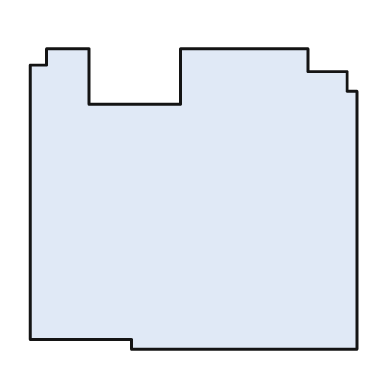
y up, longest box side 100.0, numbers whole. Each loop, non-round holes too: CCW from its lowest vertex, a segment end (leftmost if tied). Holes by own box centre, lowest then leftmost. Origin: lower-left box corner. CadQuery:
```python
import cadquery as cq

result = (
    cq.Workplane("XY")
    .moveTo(31.0, 0.0)
    .lineTo(100.0, 0.0)
    .lineTo(100.0, 79.0)
    .lineTo(97.0, 79.0)
    .lineTo(97.0, 85.0)
    .lineTo(85.0, 85.0)
    .lineTo(85.0, 92.0)
    .lineTo(46.0, 92.0)
    .lineTo(46.0, 75.0)
    .lineTo(18.0, 75.0)
    .lineTo(18.0, 92.0)
    .lineTo(5.0, 92.0)
    .lineTo(5.0, 87.0)
    .lineTo(0.0, 87.0)
    .lineTo(0.0, 3.0)
    .lineTo(31.0, 3.0)
    .close()
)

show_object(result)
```